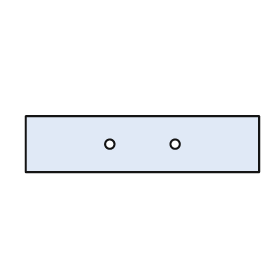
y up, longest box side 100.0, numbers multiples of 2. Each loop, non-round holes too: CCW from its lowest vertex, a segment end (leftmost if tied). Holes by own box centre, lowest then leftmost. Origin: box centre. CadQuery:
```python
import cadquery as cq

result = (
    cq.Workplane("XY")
    .moveTo(-50.0, -12.0)
    .lineTo(50.0, -12.0)
    .lineTo(50.0, 12.0)
    .lineTo(-50.0, 12.0)
    .close()
    .moveTo(-14.0, 0.0)
    .circle(2.0)
    .moveTo(14.0, 0.0)
    .circle(2.0)
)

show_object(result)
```